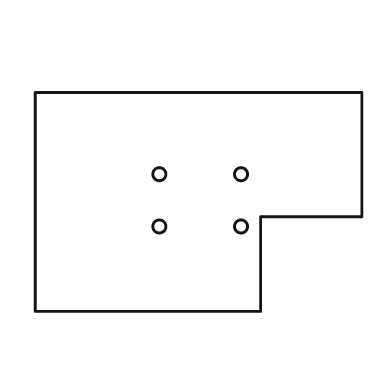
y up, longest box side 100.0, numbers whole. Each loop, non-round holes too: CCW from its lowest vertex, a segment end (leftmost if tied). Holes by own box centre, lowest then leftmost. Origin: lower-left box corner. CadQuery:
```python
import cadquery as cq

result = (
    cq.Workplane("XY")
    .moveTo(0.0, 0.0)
    .lineTo(69.0, 0.0)
    .lineTo(69.0, 29.0)
    .lineTo(100.0, 29.0)
    .lineTo(100.0, 67.0)
    .lineTo(0.0, 67.0)
    .close()
    .moveTo(38.0, 26.0)
    .circle(2.0)
    .moveTo(63.0, 26.0)
    .circle(2.0)
    .moveTo(38.0, 42.0)
    .circle(2.0)
    .moveTo(63.0, 42.0)
    .circle(2.0)
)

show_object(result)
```